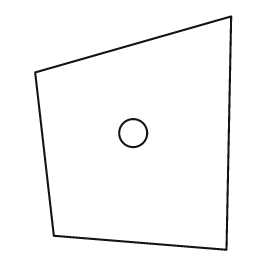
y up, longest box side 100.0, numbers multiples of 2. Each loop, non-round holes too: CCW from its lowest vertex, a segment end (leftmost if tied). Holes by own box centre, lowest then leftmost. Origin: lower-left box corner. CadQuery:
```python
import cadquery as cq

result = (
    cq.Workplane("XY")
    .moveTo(82.0, 0.0)
    .lineTo(84.0, 100.0)
    .lineTo(0.0, 76.0)
    .lineTo(8.0, 6.0)
    .close()
    .moveTo(42.0, 50.0)
    .circle(6.0)
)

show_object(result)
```